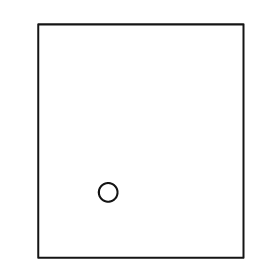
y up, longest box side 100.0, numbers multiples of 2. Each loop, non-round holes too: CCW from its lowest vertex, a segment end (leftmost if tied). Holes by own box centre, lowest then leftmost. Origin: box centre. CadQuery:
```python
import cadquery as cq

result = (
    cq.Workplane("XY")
    .moveTo(-44.0, -50.0)
    .lineTo(44.0, -50.0)
    .lineTo(44.0, 50.0)
    .lineTo(-44.0, 50.0)
    .close()
    .moveTo(-14.0, -22.0)
    .circle(4.0)
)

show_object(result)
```